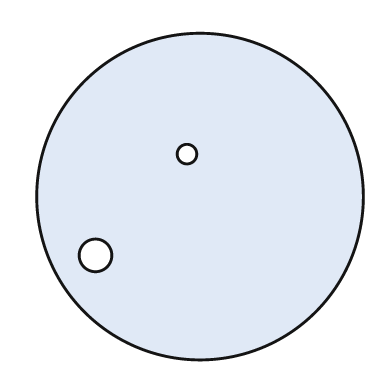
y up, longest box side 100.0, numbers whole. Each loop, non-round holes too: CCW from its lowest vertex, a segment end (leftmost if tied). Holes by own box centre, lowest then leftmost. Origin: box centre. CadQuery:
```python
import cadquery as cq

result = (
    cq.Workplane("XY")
    .moveTo(0.0, 0.0)
    .circle(50.0)
    .moveTo(-32.0, -18.0)
    .circle(5.0)
    .moveTo(-4.0, 13.0)
    .circle(3.0)
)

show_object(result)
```